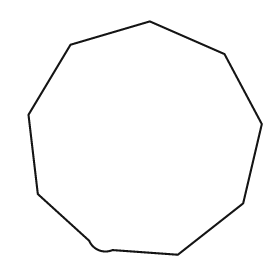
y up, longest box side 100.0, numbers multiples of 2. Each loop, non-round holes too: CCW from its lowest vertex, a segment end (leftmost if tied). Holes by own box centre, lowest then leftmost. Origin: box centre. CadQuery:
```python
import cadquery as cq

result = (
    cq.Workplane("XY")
    .moveTo(14.0, -50.0)
    .lineTo(42.0, -28.0)
    .lineTo(50.0, 6.0)
    .lineTo(34.0, 36.0)
    .lineTo(2.0, 50.0)
    .lineTo(-32.0, 40.0)
    .lineTo(-50.0, 10.0)
    .lineTo(-46.0, -24.0)
    .lineTo(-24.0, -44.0)
    .threePointArc((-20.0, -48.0), (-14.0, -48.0))
    .close()
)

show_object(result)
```